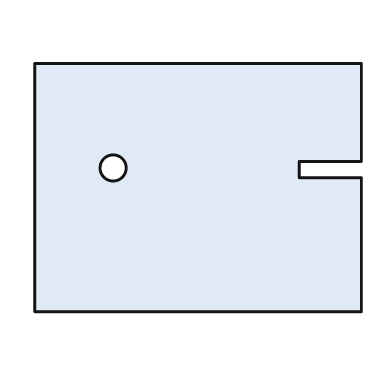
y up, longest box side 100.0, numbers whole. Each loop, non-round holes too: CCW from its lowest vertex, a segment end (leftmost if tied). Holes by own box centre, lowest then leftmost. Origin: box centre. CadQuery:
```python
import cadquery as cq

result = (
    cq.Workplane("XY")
    .moveTo(-50.0, -38.0)
    .lineTo(50.0, -38.0)
    .lineTo(50.0, 3.0)
    .lineTo(31.0, 3.0)
    .lineTo(31.0, 8.0)
    .lineTo(50.0, 8.0)
    .lineTo(50.0, 38.0)
    .lineTo(-50.0, 38.0)
    .close()
    .moveTo(-26.0, 6.0)
    .circle(4.0)
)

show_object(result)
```